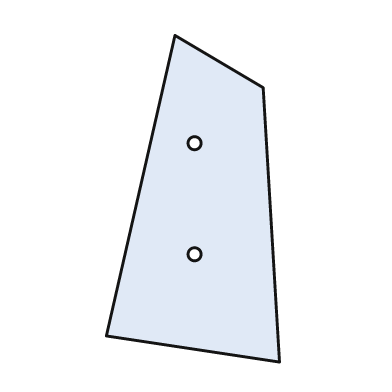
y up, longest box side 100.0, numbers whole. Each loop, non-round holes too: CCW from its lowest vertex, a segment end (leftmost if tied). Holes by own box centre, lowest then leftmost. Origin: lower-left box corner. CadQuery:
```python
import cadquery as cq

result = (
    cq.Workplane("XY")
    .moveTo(53.0, 0.0)
    .lineTo(48.0, 84.0)
    .lineTo(21.0, 100.0)
    .lineTo(0.0, 8.0)
    .close()
    .moveTo(27.0, 33.0)
    .circle(2.0)
    .moveTo(27.0, 67.0)
    .circle(2.0)
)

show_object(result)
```